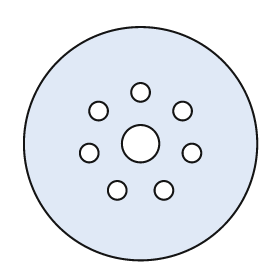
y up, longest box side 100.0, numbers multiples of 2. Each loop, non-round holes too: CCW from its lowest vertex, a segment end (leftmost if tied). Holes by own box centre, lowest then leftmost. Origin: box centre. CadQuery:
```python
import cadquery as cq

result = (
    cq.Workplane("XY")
    .moveTo(0.0, 0.0)
    .circle(50.0)
    .moveTo(-10.0, -20.0)
    .circle(4.0)
    .moveTo(10.0, -20.0)
    .circle(4.0)
    .moveTo(-22.0, -4.0)
    .circle(4.0)
    .moveTo(22.0, -4.0)
    .circle(4.0)
    .moveTo(0.0, 0.0)
    .circle(8.0)
    .moveTo(-18.0, 14.0)
    .circle(4.0)
    .moveTo(18.0, 14.0)
    .circle(4.0)
    .moveTo(0.0, 22.0)
    .circle(4.0)
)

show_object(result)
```